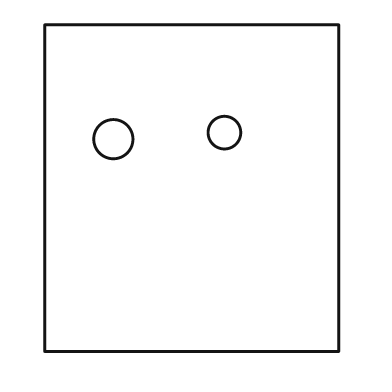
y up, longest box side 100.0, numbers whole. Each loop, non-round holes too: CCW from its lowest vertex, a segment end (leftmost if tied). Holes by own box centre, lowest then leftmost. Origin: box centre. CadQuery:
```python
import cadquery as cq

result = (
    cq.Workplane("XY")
    .moveTo(-45.0, -50.0)
    .lineTo(45.0, -50.0)
    .lineTo(45.0, 50.0)
    .lineTo(-45.0, 50.0)
    .close()
    .moveTo(-24.0, 15.0)
    .circle(6.0)
    .moveTo(10.0, 17.0)
    .circle(5.0)
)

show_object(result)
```